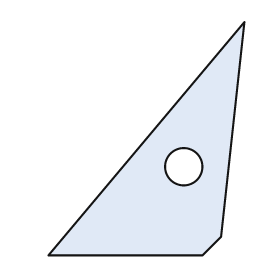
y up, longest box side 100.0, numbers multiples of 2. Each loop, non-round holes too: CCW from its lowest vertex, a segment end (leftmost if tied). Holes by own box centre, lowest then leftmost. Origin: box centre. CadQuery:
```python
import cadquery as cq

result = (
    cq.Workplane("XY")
    .moveTo(-42.0, -50.0)
    .lineTo(24.0, -50.0)
    .lineTo(32.0, -42.0)
    .lineTo(42.0, 50.0)
    .close()
    .moveTo(16.0, -12.0)
    .circle(8.0)
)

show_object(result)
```